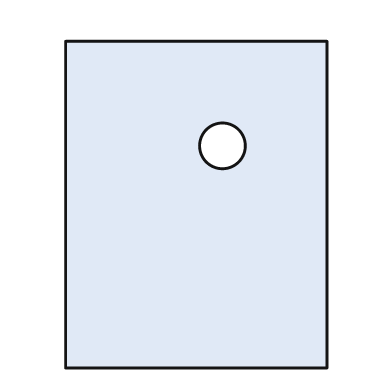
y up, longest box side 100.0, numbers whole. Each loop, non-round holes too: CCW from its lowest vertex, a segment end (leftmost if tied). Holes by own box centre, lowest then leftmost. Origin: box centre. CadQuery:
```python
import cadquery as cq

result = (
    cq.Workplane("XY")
    .moveTo(-40.0, -50.0)
    .lineTo(40.0, -50.0)
    .lineTo(40.0, 50.0)
    .lineTo(-40.0, 50.0)
    .close()
    .moveTo(8.0, 18.0)
    .circle(7.0)
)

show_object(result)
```